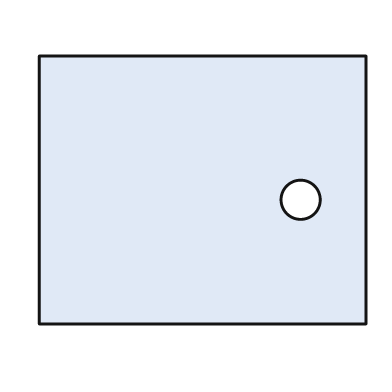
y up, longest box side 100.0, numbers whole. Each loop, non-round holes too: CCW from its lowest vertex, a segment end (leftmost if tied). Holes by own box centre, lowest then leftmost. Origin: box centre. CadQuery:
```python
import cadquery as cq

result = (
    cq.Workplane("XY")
    .moveTo(-50.0, -41.0)
    .lineTo(50.0, -41.0)
    .lineTo(50.0, 41.0)
    .lineTo(-50.0, 41.0)
    .close()
    .moveTo(30.0, -3.0)
    .circle(6.0)
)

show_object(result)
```